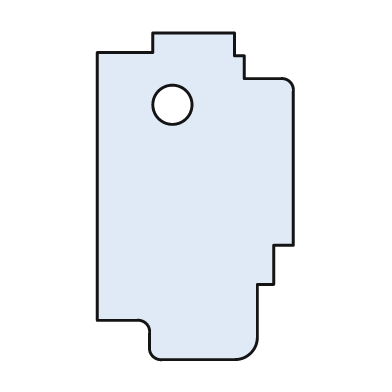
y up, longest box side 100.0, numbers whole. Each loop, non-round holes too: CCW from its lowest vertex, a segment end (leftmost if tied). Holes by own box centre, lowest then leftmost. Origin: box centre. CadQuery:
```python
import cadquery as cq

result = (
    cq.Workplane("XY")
    .moveTo(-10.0, -50.0)
    .lineTo(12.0, -50.0)
    .threePointArc((17.0, -48.0), (19.0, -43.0))
    .lineTo(19.0, -27.0)
    .lineTo(24.0, -27.0)
    .lineTo(24.0, -15.0)
    .lineTo(30.0, -15.0)
    .lineTo(30.0, 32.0)
    .threePointArc((29.0, 35.0), (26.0, 36.0))
    .lineTo(15.0, 36.0)
    .lineTo(15.0, 43.0)
    .lineTo(12.0, 43.0)
    .lineTo(12.0, 50.0)
    .lineTo(-13.0, 50.0)
    .lineTo(-13.0, 44.0)
    .lineTo(-30.0, 44.0)
    .lineTo(-30.0, -38.0)
    .lineTo(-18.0, -38.0)
    .threePointArc((-15.0, -39.0), (-14.0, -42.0))
    .lineTo(-14.0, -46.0)
    .threePointArc((-13.0, -49.0), (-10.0, -50.0))
    .close()
    .moveTo(-7.0, 28.0)
    .circle(6.0)
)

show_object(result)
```